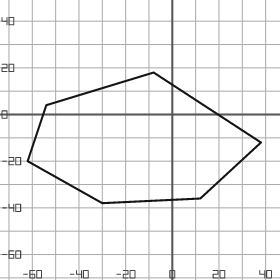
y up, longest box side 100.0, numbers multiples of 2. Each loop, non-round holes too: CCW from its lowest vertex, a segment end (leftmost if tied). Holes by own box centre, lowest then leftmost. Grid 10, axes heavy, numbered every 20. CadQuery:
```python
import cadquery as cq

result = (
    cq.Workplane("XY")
    .moveTo(-30.0, -38.0)
    .lineTo(12.0, -36.0)
    .lineTo(38.0, -12.0)
    .lineTo(-8.0, 18.0)
    .lineTo(-54.0, 4.0)
    .lineTo(-62.0, -20.0)
    .close()
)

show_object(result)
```